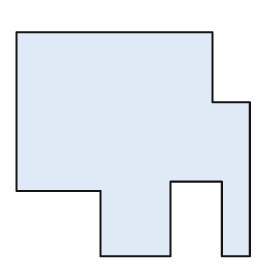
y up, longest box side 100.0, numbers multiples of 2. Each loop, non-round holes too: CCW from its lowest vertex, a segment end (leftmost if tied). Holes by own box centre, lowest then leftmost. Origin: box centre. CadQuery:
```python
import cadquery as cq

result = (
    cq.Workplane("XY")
    .moveTo(-14.0, -48.0)
    .lineTo(16.0, -48.0)
    .lineTo(16.0, -16.0)
    .lineTo(38.0, -16.0)
    .lineTo(38.0, -48.0)
    .lineTo(50.0, -48.0)
    .lineTo(50.0, 18.0)
    .lineTo(34.0, 18.0)
    .lineTo(34.0, 48.0)
    .lineTo(-50.0, 48.0)
    .lineTo(-50.0, -20.0)
    .lineTo(-14.0, -20.0)
    .close()
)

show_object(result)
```